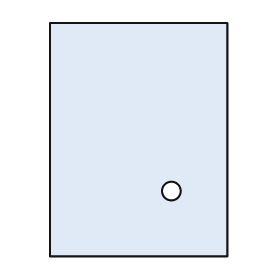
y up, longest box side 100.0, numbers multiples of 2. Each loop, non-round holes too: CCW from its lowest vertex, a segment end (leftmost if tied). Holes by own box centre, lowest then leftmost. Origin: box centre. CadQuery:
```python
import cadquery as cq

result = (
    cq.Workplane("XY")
    .moveTo(-38.0, -50.0)
    .lineTo(38.0, -50.0)
    .lineTo(38.0, 50.0)
    .lineTo(-38.0, 50.0)
    .close()
    .moveTo(14.0, -22.0)
    .circle(4.0)
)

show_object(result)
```